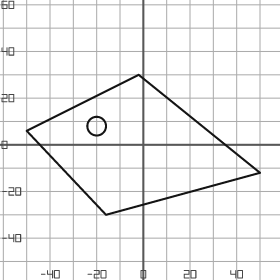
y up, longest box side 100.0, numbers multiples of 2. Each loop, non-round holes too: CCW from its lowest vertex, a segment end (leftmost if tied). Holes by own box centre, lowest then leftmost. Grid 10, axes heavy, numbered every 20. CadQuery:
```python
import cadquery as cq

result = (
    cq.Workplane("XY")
    .moveTo(-16.0, -30.0)
    .lineTo(50.0, -12.0)
    .lineTo(-2.0, 30.0)
    .lineTo(-50.0, 6.0)
    .close()
    .moveTo(-20.0, 8.0)
    .circle(4.0)
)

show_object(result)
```